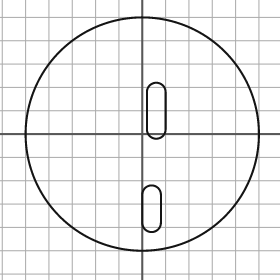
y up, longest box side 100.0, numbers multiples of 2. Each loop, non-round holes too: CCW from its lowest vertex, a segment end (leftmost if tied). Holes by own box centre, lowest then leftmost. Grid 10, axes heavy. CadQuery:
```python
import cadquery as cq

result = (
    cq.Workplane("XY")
    .moveTo(0.0, 0.0)
    .circle(50.0)
    .moveTo(0.0, -38.0)
    .threePointArc((4.0, -42.0), (8.0, -38.0))
    .lineTo(8.0, -26.0)
    .threePointArc((4.0, -22.0), (0.0, -26.0))
    .close()
    .moveTo(2.0, 2.0)
    .threePointArc((6.0, -2.0), (10.0, 2.0))
    .lineTo(10.0, 18.0)
    .threePointArc((6.0, 22.0), (2.0, 18.0))
    .close()
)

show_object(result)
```